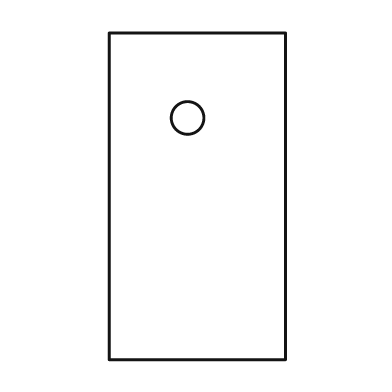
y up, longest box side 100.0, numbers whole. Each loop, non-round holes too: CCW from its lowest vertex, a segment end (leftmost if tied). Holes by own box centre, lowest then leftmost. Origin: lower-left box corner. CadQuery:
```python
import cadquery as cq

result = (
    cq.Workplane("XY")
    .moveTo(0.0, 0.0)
    .lineTo(54.0, 0.0)
    .lineTo(54.0, 100.0)
    .lineTo(0.0, 100.0)
    .close()
    .moveTo(24.0, 74.0)
    .circle(5.0)
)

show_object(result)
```